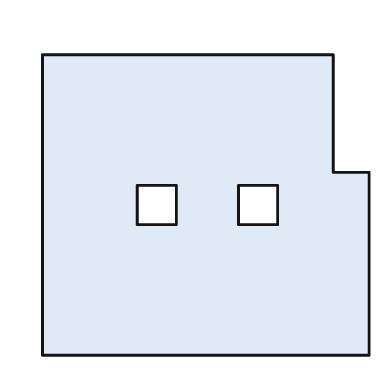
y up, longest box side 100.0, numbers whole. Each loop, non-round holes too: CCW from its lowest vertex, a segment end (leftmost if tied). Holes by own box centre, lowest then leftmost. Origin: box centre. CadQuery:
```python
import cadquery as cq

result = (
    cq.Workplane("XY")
    .moveTo(-50.0, -46.0)
    .lineTo(50.0, -46.0)
    .lineTo(50.0, 10.0)
    .lineTo(39.0, 10.0)
    .lineTo(39.0, 46.0)
    .lineTo(-50.0, 46.0)
    .close()
    .moveTo(-21.0, -6.0)
    .lineTo(-9.0, -6.0)
    .lineTo(-9.0, 6.0)
    .lineTo(-21.0, 6.0)
    .close()
    .moveTo(10.0, -6.0)
    .lineTo(22.0, -6.0)
    .lineTo(22.0, 6.0)
    .lineTo(10.0, 6.0)
    .close()
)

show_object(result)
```